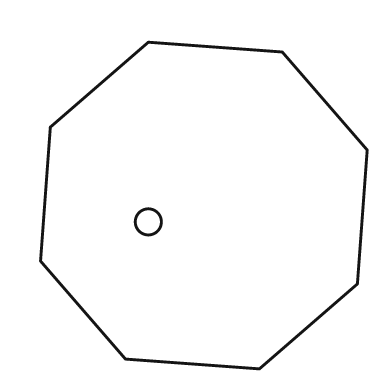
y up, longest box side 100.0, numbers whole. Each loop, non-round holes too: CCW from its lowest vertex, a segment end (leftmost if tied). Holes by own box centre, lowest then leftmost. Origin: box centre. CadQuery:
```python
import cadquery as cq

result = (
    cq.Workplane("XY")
    .moveTo(17.0, -50.0)
    .lineTo(47.0, -24.0)
    .lineTo(50.0, 17.0)
    .lineTo(24.0, 47.0)
    .lineTo(-17.0, 50.0)
    .lineTo(-47.0, 24.0)
    .lineTo(-50.0, -17.0)
    .lineTo(-24.0, -47.0)
    .close()
    .moveTo(-17.0, -5.0)
    .circle(4.0)
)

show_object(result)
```